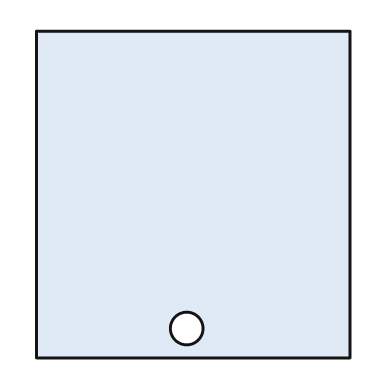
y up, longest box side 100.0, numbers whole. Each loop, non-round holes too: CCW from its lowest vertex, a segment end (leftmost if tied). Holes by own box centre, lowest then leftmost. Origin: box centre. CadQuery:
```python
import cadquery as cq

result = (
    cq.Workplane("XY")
    .moveTo(-48.0, -50.0)
    .lineTo(48.0, -50.0)
    .lineTo(48.0, 50.0)
    .lineTo(-48.0, 50.0)
    .close()
    .moveTo(-2.0, -41.0)
    .circle(5.0)
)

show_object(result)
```